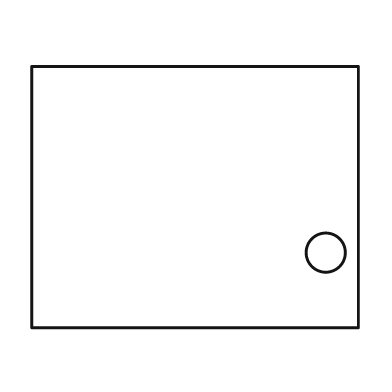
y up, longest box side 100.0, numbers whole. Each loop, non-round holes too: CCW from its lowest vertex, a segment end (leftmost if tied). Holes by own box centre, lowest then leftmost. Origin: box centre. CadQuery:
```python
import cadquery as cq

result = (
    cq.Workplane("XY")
    .moveTo(-50.0, -40.0)
    .lineTo(50.0, -40.0)
    .lineTo(50.0, 40.0)
    .lineTo(-50.0, 40.0)
    .close()
    .moveTo(40.0, -17.0)
    .circle(6.0)
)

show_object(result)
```